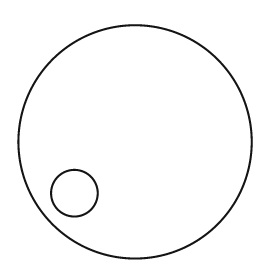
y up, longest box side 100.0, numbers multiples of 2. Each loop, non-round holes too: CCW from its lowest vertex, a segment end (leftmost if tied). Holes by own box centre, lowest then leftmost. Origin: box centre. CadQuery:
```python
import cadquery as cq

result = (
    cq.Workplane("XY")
    .moveTo(0.0, 0.0)
    .circle(50.0)
    .moveTo(-26.0, -22.0)
    .circle(10.0)
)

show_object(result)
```